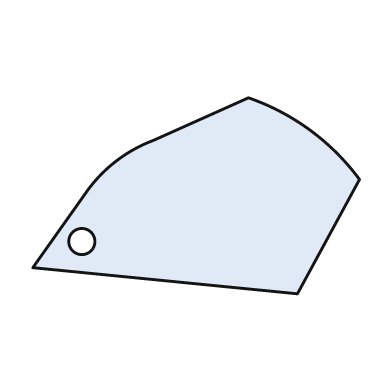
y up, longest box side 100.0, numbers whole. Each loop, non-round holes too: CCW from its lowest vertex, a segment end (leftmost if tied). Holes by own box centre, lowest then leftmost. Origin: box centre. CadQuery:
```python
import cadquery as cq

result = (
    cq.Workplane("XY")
    .moveTo(31.0, -30.0)
    .lineTo(50.0, 5.0)
    .threePointArc((35.0, 20.0), (16.0, 30.0))
    .lineTo(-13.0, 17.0)
    .threePointArc((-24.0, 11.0), (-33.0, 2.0))
    .lineTo(-50.0, -22.0)
    .close()
    .moveTo(-35.0, -14.0)
    .circle(4.0)
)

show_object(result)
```